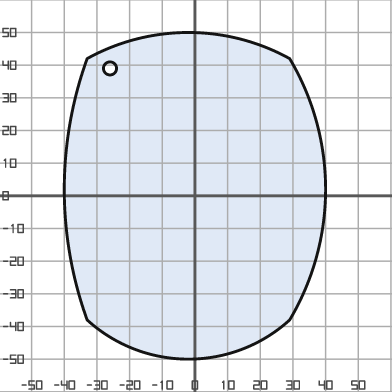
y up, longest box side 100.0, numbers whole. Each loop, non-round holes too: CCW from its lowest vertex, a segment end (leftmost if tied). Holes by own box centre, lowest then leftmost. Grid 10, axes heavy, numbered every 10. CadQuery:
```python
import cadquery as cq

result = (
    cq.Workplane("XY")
    .moveTo(-33.0, -38.0)
    .threePointArc((-2.0, -50.0), (29.0, -38.0))
    .threePointArc((40.0, 2.0), (29.0, 42.0))
    .threePointArc((-2.0, 50.0), (-33.0, 42.0))
    .threePointArc((-40.0, 2.0), (-33.0, -38.0))
    .close()
    .moveTo(-26.0, 39.0)
    .circle(2.0)
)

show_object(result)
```